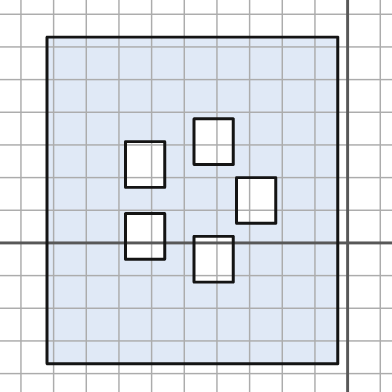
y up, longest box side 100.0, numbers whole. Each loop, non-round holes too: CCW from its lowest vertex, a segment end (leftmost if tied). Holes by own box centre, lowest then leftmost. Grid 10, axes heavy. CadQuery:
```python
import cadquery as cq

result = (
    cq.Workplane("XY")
    .moveTo(-92.0, -37.0)
    .lineTo(-3.0, -37.0)
    .lineTo(-3.0, 63.0)
    .lineTo(-92.0, 63.0)
    .close()
    .moveTo(-47.0, -12.0)
    .lineTo(-35.0, -12.0)
    .lineTo(-35.0, 2.0)
    .lineTo(-47.0, 2.0)
    .close()
    .moveTo(-68.0, -5.0)
    .lineTo(-56.0, -5.0)
    .lineTo(-56.0, 9.0)
    .lineTo(-68.0, 9.0)
    .close()
    .moveTo(-34.0, 6.0)
    .lineTo(-22.0, 6.0)
    .lineTo(-22.0, 20.0)
    .lineTo(-34.0, 20.0)
    .close()
    .moveTo(-68.0, 17.0)
    .lineTo(-56.0, 17.0)
    .lineTo(-56.0, 31.0)
    .lineTo(-68.0, 31.0)
    .close()
    .moveTo(-47.0, 24.0)
    .lineTo(-35.0, 24.0)
    .lineTo(-35.0, 38.0)
    .lineTo(-47.0, 38.0)
    .close()
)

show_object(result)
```